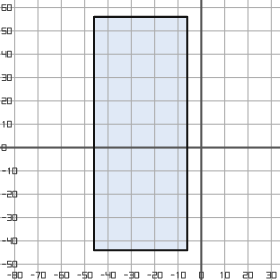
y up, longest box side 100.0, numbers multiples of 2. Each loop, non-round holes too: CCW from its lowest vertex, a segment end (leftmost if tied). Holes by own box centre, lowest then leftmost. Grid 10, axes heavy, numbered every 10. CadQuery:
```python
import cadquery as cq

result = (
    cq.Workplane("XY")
    .moveTo(-46.0, -44.0)
    .lineTo(-6.0, -44.0)
    .lineTo(-6.0, 56.0)
    .lineTo(-46.0, 56.0)
    .close()
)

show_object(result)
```